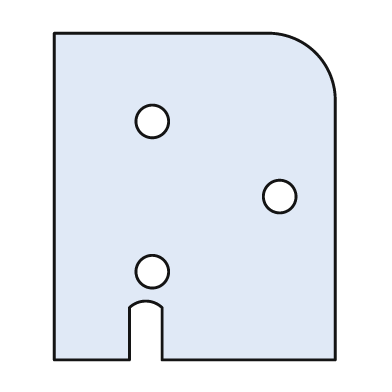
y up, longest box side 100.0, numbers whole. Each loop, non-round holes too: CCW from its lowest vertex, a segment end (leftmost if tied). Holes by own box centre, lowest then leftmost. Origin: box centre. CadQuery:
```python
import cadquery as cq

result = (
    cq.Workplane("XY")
    .moveTo(-43.0, -50.0)
    .lineTo(-20.0, -50.0)
    .lineTo(-20.0, -34.0)
    .threePointArc((-15.0, -32.0), (-10.0, -34.0))
    .lineTo(-10.0, -50.0)
    .lineTo(43.0, -50.0)
    .lineTo(43.0, 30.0)
    .threePointArc((37.0, 44.0), (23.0, 50.0))
    .lineTo(-43.0, 50.0)
    .close()
    .moveTo(-13.0, -23.0)
    .circle(5.0)
    .moveTo(26.0, 0.0)
    .circle(5.0)
    .moveTo(-13.0, 23.0)
    .circle(5.0)
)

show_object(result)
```